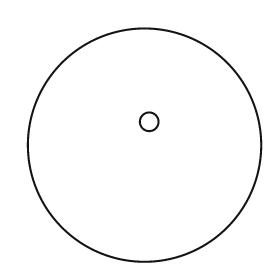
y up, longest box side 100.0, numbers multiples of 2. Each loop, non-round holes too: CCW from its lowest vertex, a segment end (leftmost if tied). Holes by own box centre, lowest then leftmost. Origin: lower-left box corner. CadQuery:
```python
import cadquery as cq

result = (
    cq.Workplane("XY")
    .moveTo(50.0, 50.0)
    .circle(50.0)
    .moveTo(52.0, 60.0)
    .circle(4.0)
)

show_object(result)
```